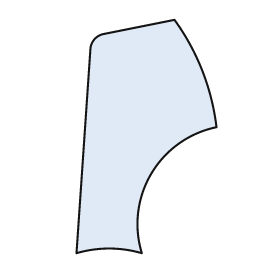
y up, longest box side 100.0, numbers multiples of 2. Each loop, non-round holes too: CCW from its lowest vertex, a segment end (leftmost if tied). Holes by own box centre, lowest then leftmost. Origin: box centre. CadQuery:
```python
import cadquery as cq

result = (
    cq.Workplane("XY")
    .moveTo(-30.0, -50.0)
    .threePointArc((-16.0, -48.0), (-2.0, -50.0))
    .threePointArc((2.0, -16.0), (30.0, 4.0))
    .threePointArc((24.0, 28.0), (12.0, 50.0))
    .lineTo(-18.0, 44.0)
    .threePointArc((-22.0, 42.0), (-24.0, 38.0))
    .close()
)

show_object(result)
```